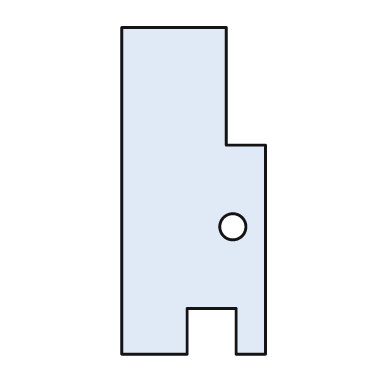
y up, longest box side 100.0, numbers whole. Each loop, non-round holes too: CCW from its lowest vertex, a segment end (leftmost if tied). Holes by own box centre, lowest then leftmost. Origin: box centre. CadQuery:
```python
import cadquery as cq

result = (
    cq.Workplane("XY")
    .moveTo(-22.0, -50.0)
    .lineTo(-2.0, -50.0)
    .lineTo(-2.0, -36.0)
    .lineTo(13.0, -36.0)
    .lineTo(13.0, -50.0)
    .lineTo(22.0, -50.0)
    .lineTo(22.0, 14.0)
    .lineTo(10.0, 14.0)
    .lineTo(10.0, 50.0)
    .lineTo(-22.0, 50.0)
    .close()
    .moveTo(12.0, -11.0)
    .circle(4.0)
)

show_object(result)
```